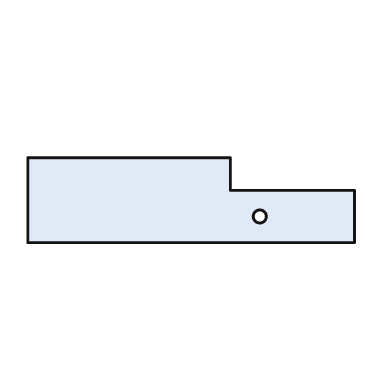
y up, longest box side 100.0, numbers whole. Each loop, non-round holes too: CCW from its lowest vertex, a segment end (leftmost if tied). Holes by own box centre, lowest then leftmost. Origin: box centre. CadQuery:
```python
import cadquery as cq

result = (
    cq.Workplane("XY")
    .moveTo(-50.0, -13.0)
    .lineTo(50.0, -13.0)
    .lineTo(50.0, 3.0)
    .lineTo(12.0, 3.0)
    .lineTo(12.0, 13.0)
    .lineTo(-50.0, 13.0)
    .close()
    .moveTo(21.0, -5.0)
    .circle(2.0)
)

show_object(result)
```